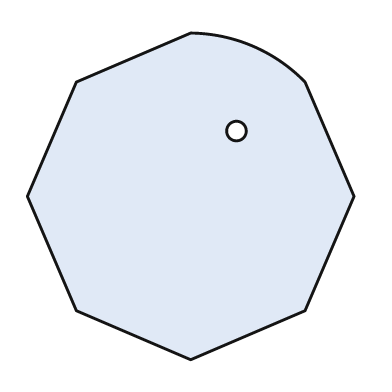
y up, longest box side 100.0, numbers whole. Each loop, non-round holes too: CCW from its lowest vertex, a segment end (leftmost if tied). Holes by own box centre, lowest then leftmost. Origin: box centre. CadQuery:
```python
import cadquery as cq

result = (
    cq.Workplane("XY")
    .moveTo(0.0, -50.0)
    .lineTo(35.0, -35.0)
    .lineTo(50.0, 0.0)
    .lineTo(35.0, 35.0)
    .threePointArc((19.0, 46.0), (0.0, 50.0))
    .lineTo(-35.0, 35.0)
    .lineTo(-50.0, 0.0)
    .lineTo(-35.0, -35.0)
    .close()
    .moveTo(14.0, 20.0)
    .circle(3.0)
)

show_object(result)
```